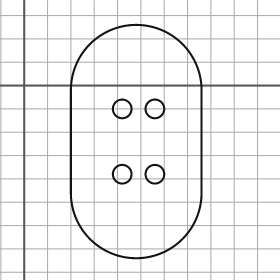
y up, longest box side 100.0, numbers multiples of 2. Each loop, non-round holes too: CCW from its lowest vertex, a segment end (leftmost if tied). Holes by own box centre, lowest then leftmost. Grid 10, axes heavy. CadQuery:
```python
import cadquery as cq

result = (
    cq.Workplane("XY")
    .moveTo(20.0, -46.0)
    .threePointArc((48.0, -74.0), (76.0, -46.0))
    .lineTo(76.0, -2.0)
    .threePointArc((48.0, 26.0), (20.0, -2.0))
    .close()
    .moveTo(42.0, -38.0)
    .circle(4.0)
    .moveTo(56.0, -38.0)
    .circle(4.0)
    .moveTo(42.0, -10.0)
    .circle(4.0)
    .moveTo(56.0, -10.0)
    .circle(4.0)
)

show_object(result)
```